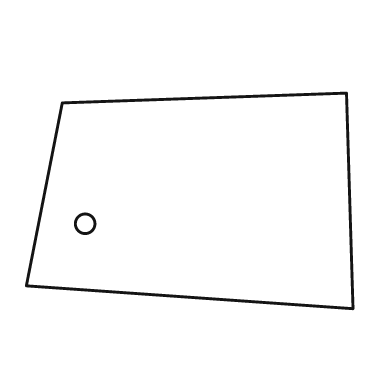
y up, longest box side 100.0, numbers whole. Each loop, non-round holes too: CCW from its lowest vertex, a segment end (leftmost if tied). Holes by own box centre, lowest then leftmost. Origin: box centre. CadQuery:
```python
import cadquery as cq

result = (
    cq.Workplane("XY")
    .moveTo(50.0, -33.0)
    .lineTo(48.0, 33.0)
    .lineTo(-39.0, 30.0)
    .lineTo(-50.0, -26.0)
    .close()
    .moveTo(-32.0, -7.0)
    .circle(3.0)
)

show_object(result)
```